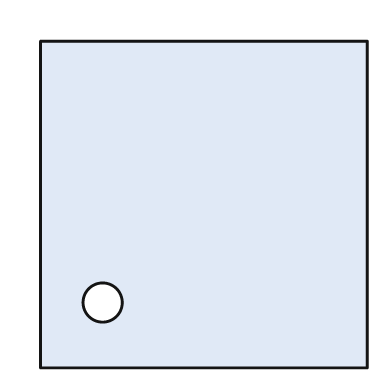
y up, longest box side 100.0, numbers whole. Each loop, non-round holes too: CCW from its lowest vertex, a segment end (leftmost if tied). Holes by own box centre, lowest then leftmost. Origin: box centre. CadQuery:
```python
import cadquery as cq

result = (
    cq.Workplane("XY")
    .moveTo(-50.0, -50.0)
    .lineTo(50.0, -50.0)
    .lineTo(50.0, 50.0)
    .lineTo(-50.0, 50.0)
    .close()
    .moveTo(-31.0, -30.0)
    .circle(6.0)
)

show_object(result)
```